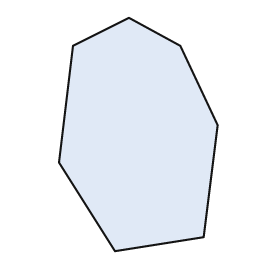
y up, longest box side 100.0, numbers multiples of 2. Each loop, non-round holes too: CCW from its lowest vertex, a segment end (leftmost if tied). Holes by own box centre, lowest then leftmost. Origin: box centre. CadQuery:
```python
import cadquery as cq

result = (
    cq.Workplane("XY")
    .moveTo(-10.0, -50.0)
    .lineTo(28.0, -44.0)
    .lineTo(34.0, 4.0)
    .lineTo(18.0, 38.0)
    .lineTo(-4.0, 50.0)
    .lineTo(-28.0, 38.0)
    .lineTo(-34.0, -12.0)
    .close()
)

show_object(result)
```